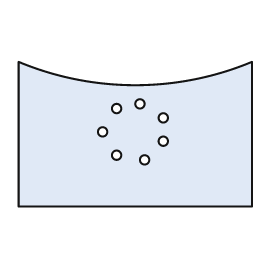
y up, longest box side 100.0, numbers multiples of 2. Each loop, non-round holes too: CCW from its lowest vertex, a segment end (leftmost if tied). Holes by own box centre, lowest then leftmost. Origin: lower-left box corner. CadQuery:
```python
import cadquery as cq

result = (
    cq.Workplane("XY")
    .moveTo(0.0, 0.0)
    .lineTo(100.0, 0.0)
    .lineTo(100.0, 62.0)
    .threePointArc((50.0, 52.0), (0.0, 62.0))
    .close()
    .moveTo(54.0, 20.0)
    .circle(2.0)
    .moveTo(42.0, 22.0)
    .circle(2.0)
    .moveTo(62.0, 28.0)
    .circle(2.0)
    .moveTo(36.0, 32.0)
    .circle(2.0)
    .moveTo(62.0, 38.0)
    .circle(2.0)
    .moveTo(42.0, 42.0)
    .circle(2.0)
    .moveTo(52.0, 44.0)
    .circle(2.0)
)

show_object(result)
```